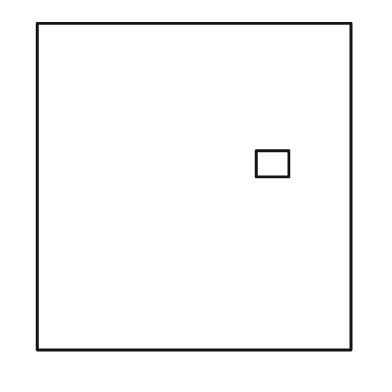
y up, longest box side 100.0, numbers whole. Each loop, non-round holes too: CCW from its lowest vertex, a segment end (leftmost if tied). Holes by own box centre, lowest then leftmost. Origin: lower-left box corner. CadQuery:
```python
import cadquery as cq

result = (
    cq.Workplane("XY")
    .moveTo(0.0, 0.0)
    .lineTo(96.0, 0.0)
    .lineTo(96.0, 100.0)
    .lineTo(0.0, 100.0)
    .close()
    .moveTo(67.0, 53.0)
    .lineTo(77.0, 53.0)
    .lineTo(77.0, 61.0)
    .lineTo(67.0, 61.0)
    .close()
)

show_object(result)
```